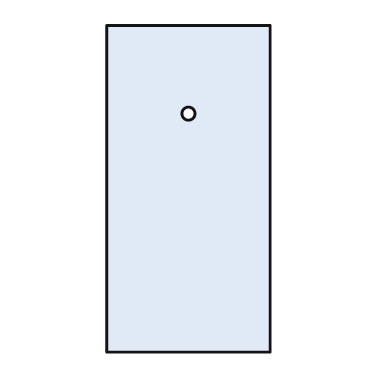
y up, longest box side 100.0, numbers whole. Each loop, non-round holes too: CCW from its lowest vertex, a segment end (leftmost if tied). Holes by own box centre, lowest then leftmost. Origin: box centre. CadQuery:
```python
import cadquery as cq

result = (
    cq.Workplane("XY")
    .moveTo(-25.0, -50.0)
    .lineTo(25.0, -50.0)
    .lineTo(25.0, 50.0)
    .lineTo(-25.0, 50.0)
    .close()
    .moveTo(0.0, 23.0)
    .circle(2.0)
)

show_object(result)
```